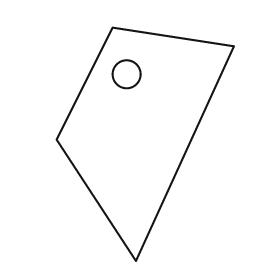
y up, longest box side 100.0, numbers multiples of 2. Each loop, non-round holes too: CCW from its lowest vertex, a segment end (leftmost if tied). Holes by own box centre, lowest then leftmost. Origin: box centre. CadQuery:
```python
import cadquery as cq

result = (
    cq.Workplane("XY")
    .moveTo(-4.0, -50.0)
    .lineTo(38.0, 42.0)
    .lineTo(-14.0, 50.0)
    .lineTo(-38.0, 2.0)
    .close()
    .moveTo(-8.0, 30.0)
    .circle(6.0)
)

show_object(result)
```